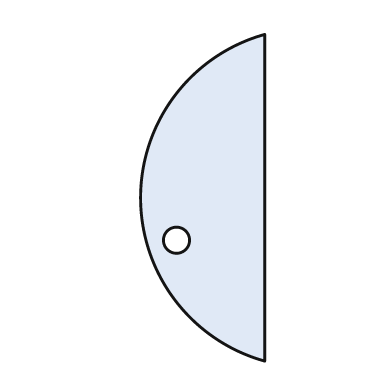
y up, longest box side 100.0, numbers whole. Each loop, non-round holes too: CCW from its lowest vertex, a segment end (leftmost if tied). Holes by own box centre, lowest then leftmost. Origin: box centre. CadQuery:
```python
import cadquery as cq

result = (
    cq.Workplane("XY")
    .moveTo(19.0, -50.0)
    .lineTo(19.0, 50.0)
    .threePointArc((-19.0, 0.0), (19.0, -50.0))
    .close()
    .moveTo(-8.0, -13.0)
    .circle(4.0)
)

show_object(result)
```